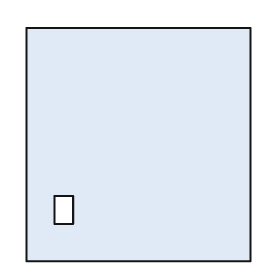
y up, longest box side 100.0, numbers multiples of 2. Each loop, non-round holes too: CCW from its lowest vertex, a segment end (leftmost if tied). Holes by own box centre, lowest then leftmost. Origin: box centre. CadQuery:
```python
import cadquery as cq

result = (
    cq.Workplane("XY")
    .moveTo(-48.0, -50.0)
    .lineTo(48.0, -50.0)
    .lineTo(48.0, 50.0)
    .lineTo(-48.0, 50.0)
    .close()
    .moveTo(-36.0, -34.0)
    .lineTo(-28.0, -34.0)
    .lineTo(-28.0, -22.0)
    .lineTo(-36.0, -22.0)
    .close()
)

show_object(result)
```